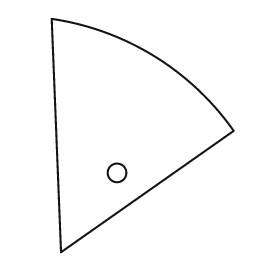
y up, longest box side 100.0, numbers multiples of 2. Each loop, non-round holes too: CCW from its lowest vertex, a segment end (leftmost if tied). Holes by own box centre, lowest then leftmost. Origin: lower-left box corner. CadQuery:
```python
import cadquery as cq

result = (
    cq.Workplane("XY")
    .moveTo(4.0, 0.0)
    .lineTo(78.0, 52.0)
    .threePointArc((44.0, 84.0), (0.0, 100.0))
    .close()
    .moveTo(28.0, 34.0)
    .circle(4.0)
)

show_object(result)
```